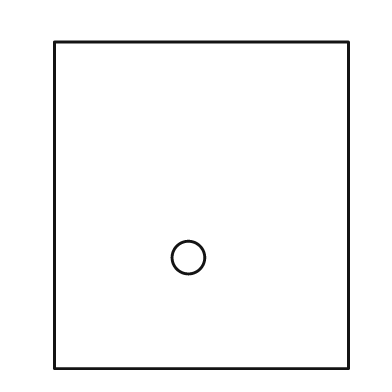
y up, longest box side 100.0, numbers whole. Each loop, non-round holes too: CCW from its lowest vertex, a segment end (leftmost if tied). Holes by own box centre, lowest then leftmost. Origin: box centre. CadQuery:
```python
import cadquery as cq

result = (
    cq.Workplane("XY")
    .moveTo(-45.0, -50.0)
    .lineTo(45.0, -50.0)
    .lineTo(45.0, 50.0)
    .lineTo(-45.0, 50.0)
    .close()
    .moveTo(-4.0, -16.0)
    .circle(5.0)
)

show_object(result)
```